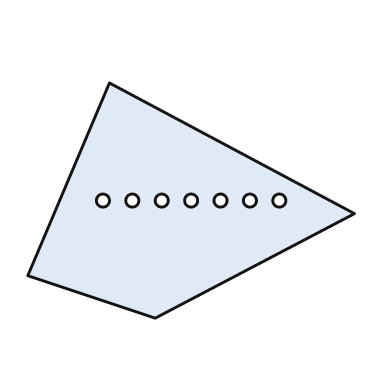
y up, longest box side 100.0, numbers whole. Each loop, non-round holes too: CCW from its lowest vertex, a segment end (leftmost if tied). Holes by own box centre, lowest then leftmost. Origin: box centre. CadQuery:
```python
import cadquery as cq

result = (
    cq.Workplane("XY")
    .moveTo(-11.0, -36.0)
    .lineTo(50.0, -4.0)
    .lineTo(-25.0, 36.0)
    .lineTo(-50.0, -23.0)
    .close()
    .moveTo(-27.0, 0.0)
    .circle(2.0)
    .moveTo(-18.0, 0.0)
    .circle(2.0)
    .moveTo(-9.0, 0.0)
    .circle(2.0)
    .moveTo(0.0, 0.0)
    .circle(2.0)
    .moveTo(9.0, 0.0)
    .circle(2.0)
    .moveTo(18.0, 0.0)
    .circle(2.0)
    .moveTo(27.0, 0.0)
    .circle(2.0)
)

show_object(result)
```